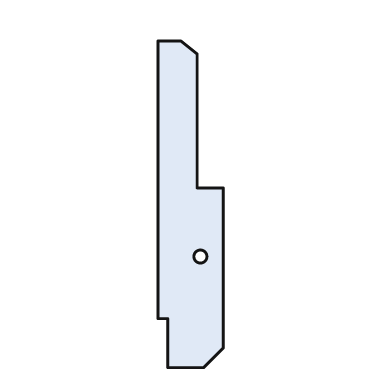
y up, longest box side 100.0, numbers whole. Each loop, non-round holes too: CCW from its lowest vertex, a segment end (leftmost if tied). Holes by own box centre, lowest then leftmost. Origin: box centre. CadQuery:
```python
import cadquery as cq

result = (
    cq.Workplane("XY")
    .moveTo(-7.0, -50.0)
    .lineTo(4.0, -50.0)
    .lineTo(10.0, -44.0)
    .lineTo(10.0, 5.0)
    .lineTo(2.0, 5.0)
    .lineTo(2.0, 46.0)
    .lineTo(-3.0, 50.0)
    .lineTo(-10.0, 50.0)
    .lineTo(-10.0, -35.0)
    .lineTo(-7.0, -35.0)
    .close()
    .moveTo(3.0, -16.0)
    .circle(2.0)
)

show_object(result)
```